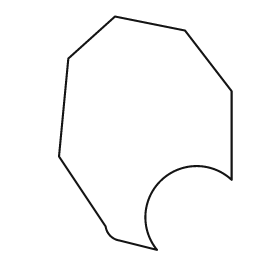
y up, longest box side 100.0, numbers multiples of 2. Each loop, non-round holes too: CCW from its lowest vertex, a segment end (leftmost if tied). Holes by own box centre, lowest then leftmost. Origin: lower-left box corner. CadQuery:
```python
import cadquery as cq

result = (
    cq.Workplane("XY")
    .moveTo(42.0, 0.0)
    .threePointArc((44.0, 30.0), (74.0, 30.0))
    .lineTo(74.0, 68.0)
    .lineTo(54.0, 94.0)
    .lineTo(24.0, 100.0)
    .lineTo(4.0, 82.0)
    .lineTo(0.0, 40.0)
    .lineTo(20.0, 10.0)
    .threePointArc((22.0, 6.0), (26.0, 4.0))
    .close()
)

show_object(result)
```